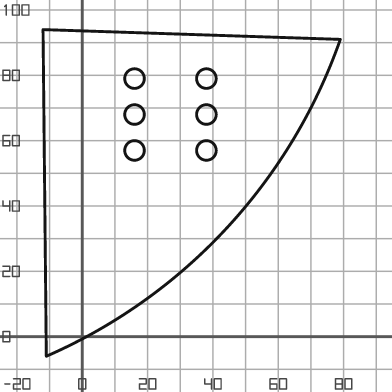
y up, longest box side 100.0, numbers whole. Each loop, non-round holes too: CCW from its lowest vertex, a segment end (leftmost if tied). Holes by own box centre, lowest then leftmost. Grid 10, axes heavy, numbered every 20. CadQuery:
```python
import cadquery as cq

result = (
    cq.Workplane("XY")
    .moveTo(-11.0, -6.0)
    .threePointArc((44.0, 33.0), (79.0, 91.0))
    .lineTo(-12.0, 94.0)
    .close()
    .moveTo(16.0, 57.0)
    .circle(3.0)
    .moveTo(38.0, 57.0)
    .circle(3.0)
    .moveTo(16.0, 68.0)
    .circle(3.0)
    .moveTo(38.0, 68.0)
    .circle(3.0)
    .moveTo(16.0, 79.0)
    .circle(3.0)
    .moveTo(38.0, 79.0)
    .circle(3.0)
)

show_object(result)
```